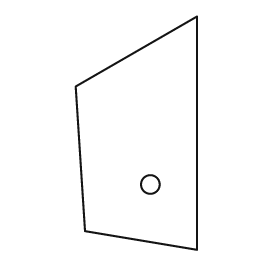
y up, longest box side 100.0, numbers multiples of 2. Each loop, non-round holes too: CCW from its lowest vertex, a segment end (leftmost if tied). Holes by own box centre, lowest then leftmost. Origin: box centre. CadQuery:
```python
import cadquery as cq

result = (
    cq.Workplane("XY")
    .moveTo(26.0, -50.0)
    .lineTo(26.0, 50.0)
    .lineTo(-26.0, 20.0)
    .lineTo(-22.0, -42.0)
    .close()
    .moveTo(6.0, -22.0)
    .circle(4.0)
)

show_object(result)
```